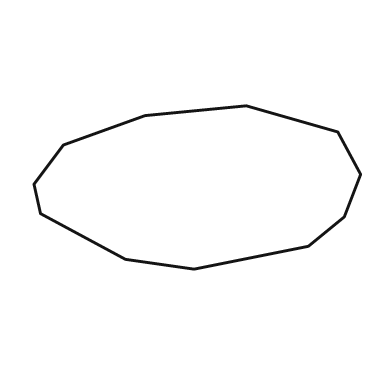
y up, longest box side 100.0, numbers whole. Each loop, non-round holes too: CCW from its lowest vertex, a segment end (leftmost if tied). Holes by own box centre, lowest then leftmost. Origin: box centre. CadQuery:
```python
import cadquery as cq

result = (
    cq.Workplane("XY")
    .moveTo(-1.0, -25.0)
    .lineTo(34.0, -18.0)
    .lineTo(45.0, -9.0)
    .lineTo(50.0, 4.0)
    .lineTo(43.0, 17.0)
    .lineTo(15.0, 25.0)
    .lineTo(-16.0, 22.0)
    .lineTo(-41.0, 13.0)
    .lineTo(-50.0, 1.0)
    .lineTo(-48.0, -8.0)
    .lineTo(-22.0, -22.0)
    .close()
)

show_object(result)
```